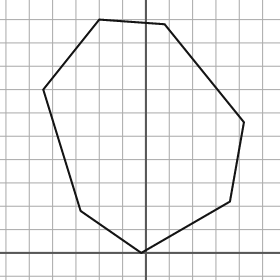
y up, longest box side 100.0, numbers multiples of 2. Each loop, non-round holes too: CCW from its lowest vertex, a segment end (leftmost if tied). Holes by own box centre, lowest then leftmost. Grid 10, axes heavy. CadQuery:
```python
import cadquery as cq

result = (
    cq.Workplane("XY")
    .moveTo(-2.0, 0.0)
    .lineTo(36.0, 22.0)
    .lineTo(42.0, 56.0)
    .lineTo(8.0, 98.0)
    .lineTo(-20.0, 100.0)
    .lineTo(-44.0, 70.0)
    .lineTo(-28.0, 18.0)
    .close()
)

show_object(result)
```